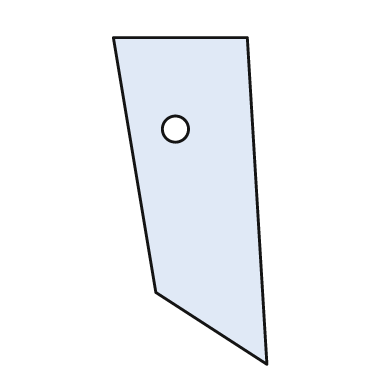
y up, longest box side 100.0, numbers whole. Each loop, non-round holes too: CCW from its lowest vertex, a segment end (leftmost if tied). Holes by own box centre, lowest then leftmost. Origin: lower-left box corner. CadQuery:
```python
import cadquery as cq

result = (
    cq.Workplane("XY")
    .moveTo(47.0, 0.0)
    .lineTo(41.0, 100.0)
    .lineTo(0.0, 100.0)
    .lineTo(13.0, 22.0)
    .close()
    .moveTo(19.0, 72.0)
    .circle(4.0)
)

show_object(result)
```